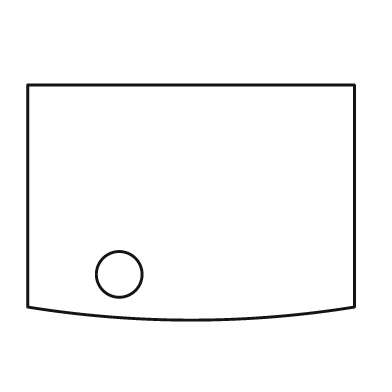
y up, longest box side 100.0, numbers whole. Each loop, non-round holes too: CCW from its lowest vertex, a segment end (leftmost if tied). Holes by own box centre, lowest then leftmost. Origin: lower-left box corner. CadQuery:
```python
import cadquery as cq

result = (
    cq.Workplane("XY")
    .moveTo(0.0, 4.0)
    .threePointArc((50.0, 0.0), (100.0, 4.0))
    .lineTo(100.0, 72.0)
    .lineTo(0.0, 72.0)
    .close()
    .moveTo(28.0, 14.0)
    .circle(7.0)
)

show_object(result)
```